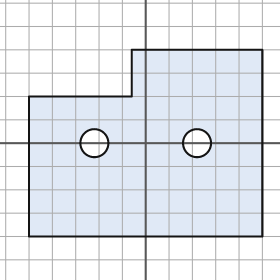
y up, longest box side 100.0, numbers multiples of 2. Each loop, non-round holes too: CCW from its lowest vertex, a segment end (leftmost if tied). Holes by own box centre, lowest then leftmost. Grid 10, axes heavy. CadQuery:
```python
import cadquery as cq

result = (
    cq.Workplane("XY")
    .moveTo(-50.0, -40.0)
    .lineTo(50.0, -40.0)
    .lineTo(50.0, 40.0)
    .lineTo(-6.0, 40.0)
    .lineTo(-6.0, 20.0)
    .lineTo(-50.0, 20.0)
    .close()
    .moveTo(-22.0, 0.0)
    .circle(6.0)
    .moveTo(22.0, 0.0)
    .circle(6.0)
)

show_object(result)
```